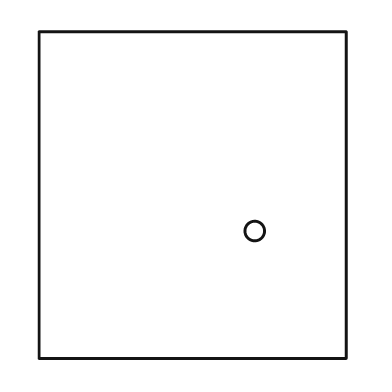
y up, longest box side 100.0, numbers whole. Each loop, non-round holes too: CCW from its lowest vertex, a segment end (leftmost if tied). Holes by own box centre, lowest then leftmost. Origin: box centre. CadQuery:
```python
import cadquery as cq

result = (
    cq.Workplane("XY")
    .moveTo(-47.0, -50.0)
    .lineTo(47.0, -50.0)
    .lineTo(47.0, 50.0)
    .lineTo(-47.0, 50.0)
    .close()
    .moveTo(19.0, -11.0)
    .circle(3.0)
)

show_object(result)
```